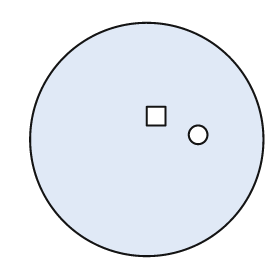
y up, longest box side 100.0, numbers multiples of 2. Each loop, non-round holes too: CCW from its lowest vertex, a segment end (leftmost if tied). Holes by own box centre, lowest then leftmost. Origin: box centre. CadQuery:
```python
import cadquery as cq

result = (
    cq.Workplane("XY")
    .moveTo(0.0, 0.0)
    .circle(50.0)
    .moveTo(22.0, 2.0)
    .circle(4.0)
    .moveTo(0.0, 6.0)
    .lineTo(8.0, 6.0)
    .lineTo(8.0, 14.0)
    .lineTo(0.0, 14.0)
    .close()
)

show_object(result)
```